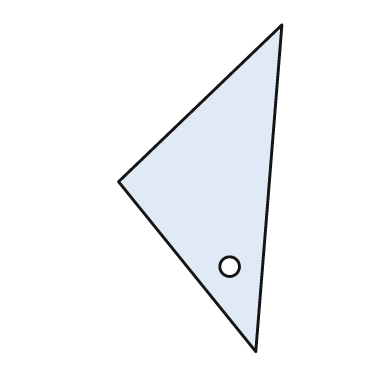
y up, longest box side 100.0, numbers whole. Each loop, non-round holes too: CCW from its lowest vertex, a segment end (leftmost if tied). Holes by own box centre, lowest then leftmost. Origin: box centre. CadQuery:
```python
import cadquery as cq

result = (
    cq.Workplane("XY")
    .moveTo(17.0, -50.0)
    .lineTo(25.0, 50.0)
    .lineTo(-25.0, 2.0)
    .close()
    .moveTo(9.0, -24.0)
    .circle(3.0)
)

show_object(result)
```